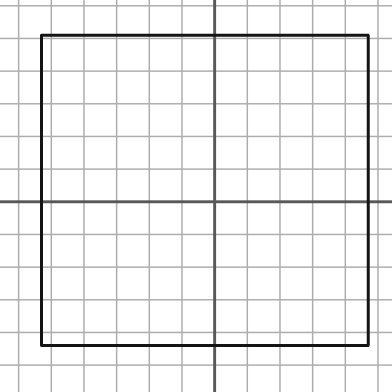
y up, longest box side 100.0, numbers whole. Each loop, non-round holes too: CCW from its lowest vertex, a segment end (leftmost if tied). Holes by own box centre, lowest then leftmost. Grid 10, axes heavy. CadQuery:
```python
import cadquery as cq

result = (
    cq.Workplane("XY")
    .moveTo(-53.0, -44.0)
    .lineTo(47.0, -44.0)
    .lineTo(47.0, 51.0)
    .lineTo(-53.0, 51.0)
    .close()
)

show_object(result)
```